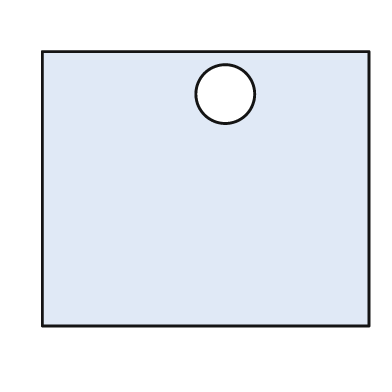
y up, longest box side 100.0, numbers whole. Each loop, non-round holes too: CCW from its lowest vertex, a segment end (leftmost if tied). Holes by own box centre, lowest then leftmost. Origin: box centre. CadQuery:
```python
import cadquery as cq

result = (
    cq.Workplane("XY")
    .moveTo(-50.0, -42.0)
    .lineTo(50.0, -42.0)
    .lineTo(50.0, 42.0)
    .lineTo(-50.0, 42.0)
    .close()
    .moveTo(6.0, 29.0)
    .circle(9.0)
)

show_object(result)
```